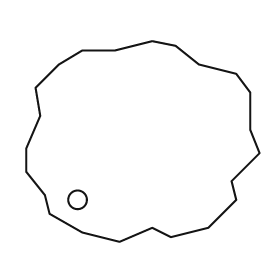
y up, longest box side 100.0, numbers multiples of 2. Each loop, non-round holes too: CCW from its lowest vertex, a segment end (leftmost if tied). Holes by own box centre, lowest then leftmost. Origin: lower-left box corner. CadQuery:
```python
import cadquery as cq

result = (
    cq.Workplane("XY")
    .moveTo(40.0, 0.0)
    .lineTo(54.0, 6.0)
    .lineTo(62.0, 2.0)
    .lineTo(78.0, 6.0)
    .lineTo(90.0, 18.0)
    .lineTo(88.0, 26.0)
    .lineTo(100.0, 38.0)
    .lineTo(96.0, 48.0)
    .lineTo(96.0, 64.0)
    .lineTo(90.0, 72.0)
    .lineTo(74.0, 76.0)
    .lineTo(64.0, 84.0)
    .lineTo(54.0, 86.0)
    .lineTo(38.0, 82.0)
    .lineTo(24.0, 82.0)
    .lineTo(14.0, 76.0)
    .lineTo(4.0, 66.0)
    .lineTo(6.0, 54.0)
    .lineTo(0.0, 40.0)
    .lineTo(0.0, 30.0)
    .lineTo(8.0, 20.0)
    .lineTo(10.0, 12.0)
    .lineTo(24.0, 4.0)
    .close()
    .moveTo(22.0, 18.0)
    .circle(4.0)
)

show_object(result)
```